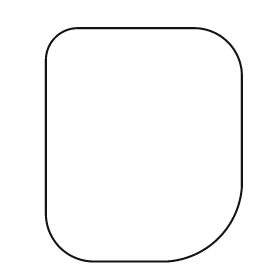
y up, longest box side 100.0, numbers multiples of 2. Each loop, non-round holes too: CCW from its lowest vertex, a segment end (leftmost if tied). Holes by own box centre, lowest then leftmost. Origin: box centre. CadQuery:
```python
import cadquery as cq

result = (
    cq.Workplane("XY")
    .moveTo(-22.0, -50.0)
    .lineTo(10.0, -50.0)
    .threePointArc((32.0, -40.0), (42.0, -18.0))
    .lineTo(42.0, 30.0)
    .threePointArc((36.0, 44.0), (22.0, 50.0))
    .lineTo(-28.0, 50.0)
    .threePointArc((-38.0, 46.0), (-42.0, 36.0))
    .lineTo(-42.0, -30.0)
    .threePointArc((-36.0, -44.0), (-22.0, -50.0))
    .close()
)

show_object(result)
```